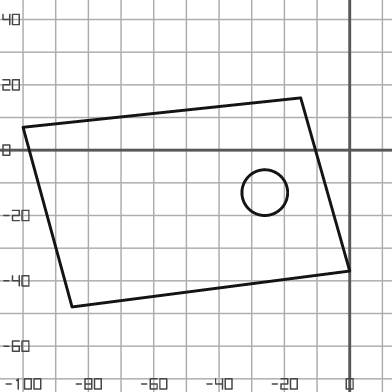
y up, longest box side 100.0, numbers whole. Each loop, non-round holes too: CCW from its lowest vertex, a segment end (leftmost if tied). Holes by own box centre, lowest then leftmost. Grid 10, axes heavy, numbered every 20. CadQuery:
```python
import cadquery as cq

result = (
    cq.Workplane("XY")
    .moveTo(-85.0, -48.0)
    .lineTo(0.0, -37.0)
    .lineTo(-15.0, 16.0)
    .lineTo(-100.0, 7.0)
    .close()
    .moveTo(-26.0, -13.0)
    .circle(7.0)
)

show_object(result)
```